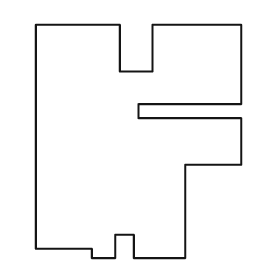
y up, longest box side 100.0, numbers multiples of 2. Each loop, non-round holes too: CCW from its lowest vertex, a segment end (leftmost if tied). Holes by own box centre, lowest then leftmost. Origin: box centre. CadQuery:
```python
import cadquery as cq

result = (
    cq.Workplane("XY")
    .moveTo(-20.0, -50.0)
    .lineTo(-10.0, -50.0)
    .lineTo(-10.0, -40.0)
    .lineTo(-2.0, -40.0)
    .lineTo(-2.0, -50.0)
    .lineTo(20.0, -50.0)
    .lineTo(20.0, -10.0)
    .lineTo(44.0, -10.0)
    .lineTo(44.0, 10.0)
    .lineTo(0.0, 10.0)
    .lineTo(0.0, 16.0)
    .lineTo(44.0, 16.0)
    .lineTo(44.0, 50.0)
    .lineTo(6.0, 50.0)
    .lineTo(6.0, 30.0)
    .lineTo(-8.0, 30.0)
    .lineTo(-8.0, 50.0)
    .lineTo(-44.0, 50.0)
    .lineTo(-44.0, -46.0)
    .lineTo(-20.0, -46.0)
    .close()
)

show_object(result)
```